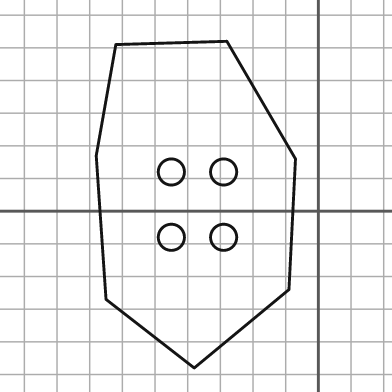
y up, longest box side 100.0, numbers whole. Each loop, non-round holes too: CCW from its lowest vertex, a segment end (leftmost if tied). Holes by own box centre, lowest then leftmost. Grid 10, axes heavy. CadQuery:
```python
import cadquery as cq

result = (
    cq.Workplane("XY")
    .moveTo(-38.0, -48.0)
    .lineTo(-9.0, -24.0)
    .lineTo(-7.0, 16.0)
    .lineTo(-28.0, 52.0)
    .lineTo(-62.0, 51.0)
    .lineTo(-68.0, 17.0)
    .lineTo(-65.0, -27.0)
    .close()
    .moveTo(-45.0, -8.0)
    .circle(4.0)
    .moveTo(-29.0, -8.0)
    .circle(4.0)
    .moveTo(-45.0, 12.0)
    .circle(4.0)
    .moveTo(-29.0, 12.0)
    .circle(4.0)
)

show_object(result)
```